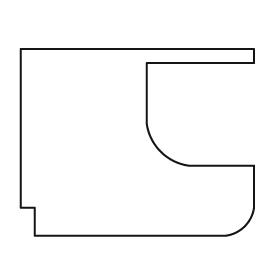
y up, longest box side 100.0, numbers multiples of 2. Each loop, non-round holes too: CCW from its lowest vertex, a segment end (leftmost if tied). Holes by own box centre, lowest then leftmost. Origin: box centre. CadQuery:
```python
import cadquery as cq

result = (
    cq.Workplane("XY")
    .moveTo(-44.0, -40.0)
    .lineTo(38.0, -40.0)
    .threePointArc((46.0, -36.0), (50.0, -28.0))
    .lineTo(50.0, -10.0)
    .lineTo(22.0, -10.0)
    .threePointArc((10.0, -4.0), (4.0, 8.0))
    .lineTo(4.0, 34.0)
    .lineTo(50.0, 34.0)
    .lineTo(50.0, 40.0)
    .lineTo(-50.0, 40.0)
    .lineTo(-50.0, -28.0)
    .lineTo(-44.0, -28.0)
    .close()
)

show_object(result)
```